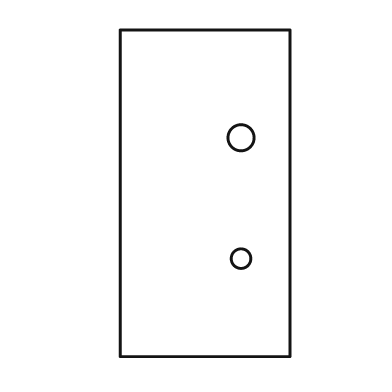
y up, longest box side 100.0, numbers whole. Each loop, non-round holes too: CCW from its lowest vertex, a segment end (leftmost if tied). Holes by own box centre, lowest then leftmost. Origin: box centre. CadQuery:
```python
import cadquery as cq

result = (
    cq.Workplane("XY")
    .moveTo(-26.0, -50.0)
    .lineTo(26.0, -50.0)
    .lineTo(26.0, 50.0)
    .lineTo(-26.0, 50.0)
    .close()
    .moveTo(11.0, -20.0)
    .circle(3.0)
    .moveTo(11.0, 17.0)
    .circle(4.0)
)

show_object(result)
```